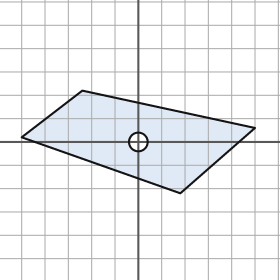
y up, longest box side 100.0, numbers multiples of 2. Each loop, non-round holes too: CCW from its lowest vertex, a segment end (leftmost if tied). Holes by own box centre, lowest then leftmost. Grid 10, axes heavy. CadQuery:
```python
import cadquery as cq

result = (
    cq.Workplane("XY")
    .moveTo(18.0, -22.0)
    .lineTo(50.0, 6.0)
    .lineTo(-24.0, 22.0)
    .lineTo(-50.0, 2.0)
    .close()
    .moveTo(0.0, 0.0)
    .circle(4.0)
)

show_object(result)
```